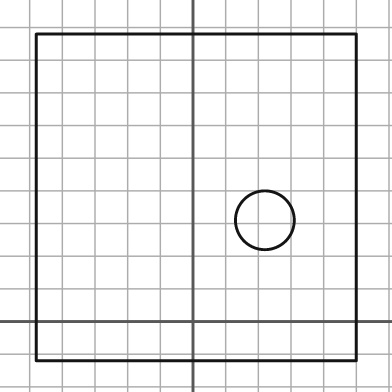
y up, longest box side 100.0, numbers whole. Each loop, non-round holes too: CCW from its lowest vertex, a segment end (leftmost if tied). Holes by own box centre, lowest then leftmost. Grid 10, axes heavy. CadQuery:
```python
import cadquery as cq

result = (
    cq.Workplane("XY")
    .moveTo(-48.0, -12.0)
    .lineTo(50.0, -12.0)
    .lineTo(50.0, 88.0)
    .lineTo(-48.0, 88.0)
    .close()
    .moveTo(22.0, 31.0)
    .circle(9.0)
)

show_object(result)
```